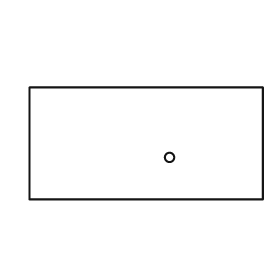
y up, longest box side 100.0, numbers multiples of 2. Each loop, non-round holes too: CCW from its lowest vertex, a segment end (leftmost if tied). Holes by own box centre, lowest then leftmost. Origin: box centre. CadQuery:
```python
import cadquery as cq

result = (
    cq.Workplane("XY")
    .moveTo(-50.0, -24.0)
    .lineTo(50.0, -24.0)
    .lineTo(50.0, 24.0)
    .lineTo(-50.0, 24.0)
    .close()
    .moveTo(10.0, -6.0)
    .circle(2.0)
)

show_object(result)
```